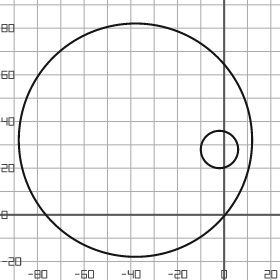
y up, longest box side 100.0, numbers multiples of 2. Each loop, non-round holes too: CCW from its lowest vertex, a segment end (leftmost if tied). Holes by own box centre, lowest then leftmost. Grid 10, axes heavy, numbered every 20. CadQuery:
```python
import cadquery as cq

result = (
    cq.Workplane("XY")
    .moveTo(-38.0, 32.0)
    .circle(50.0)
    .moveTo(-2.0, 28.0)
    .circle(8.0)
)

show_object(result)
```